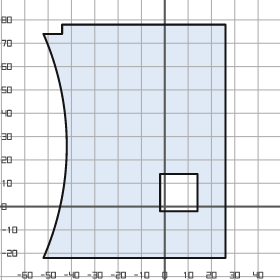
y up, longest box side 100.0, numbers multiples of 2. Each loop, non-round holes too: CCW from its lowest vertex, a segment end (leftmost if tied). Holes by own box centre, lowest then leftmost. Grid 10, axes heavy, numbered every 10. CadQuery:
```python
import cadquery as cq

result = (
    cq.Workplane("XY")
    .moveTo(-52.0, -22.0)
    .lineTo(26.0, -22.0)
    .lineTo(26.0, 78.0)
    .lineTo(-44.0, 78.0)
    .lineTo(-44.0, 74.0)
    .lineTo(-52.0, 74.0)
    .threePointArc((-42.0, 26.0), (-52.0, -22.0))
    .close()
    .moveTo(-2.0, -2.0)
    .lineTo(14.0, -2.0)
    .lineTo(14.0, 14.0)
    .lineTo(-2.0, 14.0)
    .close()
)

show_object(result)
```